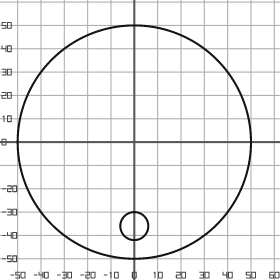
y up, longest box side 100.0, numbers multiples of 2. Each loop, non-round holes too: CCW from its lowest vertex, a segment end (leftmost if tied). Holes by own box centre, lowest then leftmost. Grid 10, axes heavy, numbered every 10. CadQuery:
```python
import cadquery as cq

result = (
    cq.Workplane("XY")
    .moveTo(0.0, 0.0)
    .circle(50.0)
    .moveTo(0.0, -36.0)
    .circle(6.0)
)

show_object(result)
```